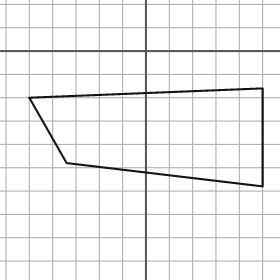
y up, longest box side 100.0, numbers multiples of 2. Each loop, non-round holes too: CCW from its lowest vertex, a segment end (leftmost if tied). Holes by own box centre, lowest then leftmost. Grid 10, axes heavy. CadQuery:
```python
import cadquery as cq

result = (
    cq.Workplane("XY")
    .moveTo(50.0, -58.0)
    .lineTo(50.0, -16.0)
    .lineTo(-50.0, -20.0)
    .lineTo(-34.0, -48.0)
    .close()
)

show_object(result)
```